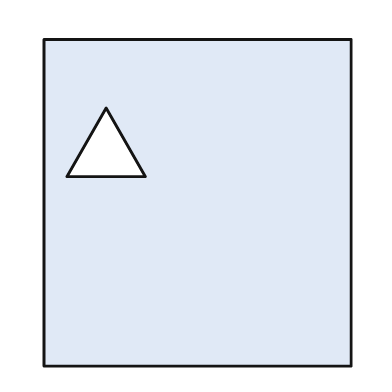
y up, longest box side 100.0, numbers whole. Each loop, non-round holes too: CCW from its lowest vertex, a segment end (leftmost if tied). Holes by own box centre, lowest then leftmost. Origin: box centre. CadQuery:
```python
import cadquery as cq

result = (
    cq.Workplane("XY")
    .moveTo(-47.0, -50.0)
    .lineTo(47.0, -50.0)
    .lineTo(47.0, 50.0)
    .lineTo(-47.0, 50.0)
    .close()
    .moveTo(-40.0, 8.0)
    .lineTo(-16.0, 8.0)
    .lineTo(-28.0, 29.0)
    .close()
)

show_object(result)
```